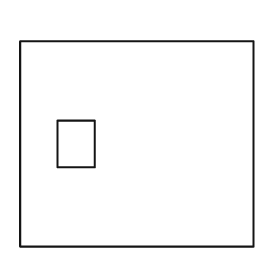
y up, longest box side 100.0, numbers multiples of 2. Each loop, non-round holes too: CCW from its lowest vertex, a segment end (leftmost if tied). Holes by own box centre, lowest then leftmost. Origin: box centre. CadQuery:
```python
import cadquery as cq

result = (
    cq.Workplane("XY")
    .moveTo(-50.0, -44.0)
    .lineTo(50.0, -44.0)
    .lineTo(50.0, 44.0)
    .lineTo(-50.0, 44.0)
    .close()
    .moveTo(-34.0, -10.0)
    .lineTo(-18.0, -10.0)
    .lineTo(-18.0, 10.0)
    .lineTo(-34.0, 10.0)
    .close()
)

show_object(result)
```